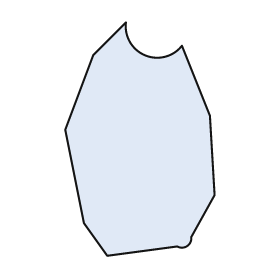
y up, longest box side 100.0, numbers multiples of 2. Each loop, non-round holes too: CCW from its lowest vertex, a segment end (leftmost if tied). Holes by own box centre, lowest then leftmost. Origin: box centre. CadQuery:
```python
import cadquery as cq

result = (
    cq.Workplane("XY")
    .moveTo(-14.0, -50.0)
    .lineTo(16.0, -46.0)
    .threePointArc((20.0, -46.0), (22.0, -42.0))
    .lineTo(32.0, -24.0)
    .lineTo(30.0, 10.0)
    .lineTo(18.0, 40.0)
    .threePointArc((2.0, 36.0), (-6.0, 50.0))
    .lineTo(-20.0, 36.0)
    .lineTo(-32.0, 4.0)
    .lineTo(-24.0, -36.0)
    .close()
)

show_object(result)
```